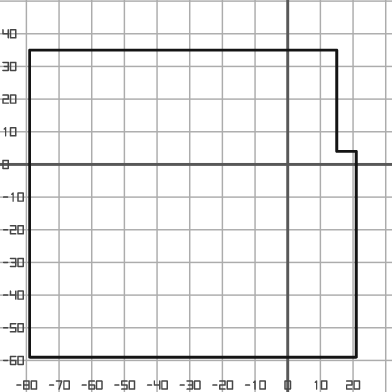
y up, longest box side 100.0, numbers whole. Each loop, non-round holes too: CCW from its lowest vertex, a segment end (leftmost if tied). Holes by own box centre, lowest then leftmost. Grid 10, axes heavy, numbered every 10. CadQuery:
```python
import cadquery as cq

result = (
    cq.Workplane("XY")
    .moveTo(-79.0, -59.0)
    .lineTo(21.0, -59.0)
    .lineTo(21.0, 4.0)
    .lineTo(15.0, 4.0)
    .lineTo(15.0, 35.0)
    .lineTo(-79.0, 35.0)
    .close()
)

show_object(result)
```